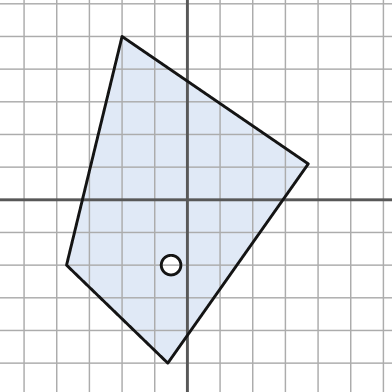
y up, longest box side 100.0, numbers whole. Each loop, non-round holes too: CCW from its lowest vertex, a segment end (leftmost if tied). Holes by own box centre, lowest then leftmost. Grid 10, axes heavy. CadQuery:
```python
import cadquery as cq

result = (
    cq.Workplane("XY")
    .moveTo(-6.0, -50.0)
    .lineTo(37.0, 11.0)
    .lineTo(-20.0, 50.0)
    .lineTo(-37.0, -20.0)
    .close()
    .moveTo(-5.0, -20.0)
    .circle(3.0)
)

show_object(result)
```